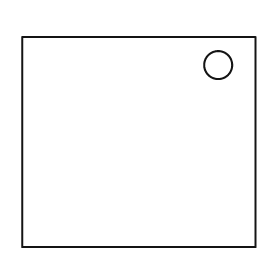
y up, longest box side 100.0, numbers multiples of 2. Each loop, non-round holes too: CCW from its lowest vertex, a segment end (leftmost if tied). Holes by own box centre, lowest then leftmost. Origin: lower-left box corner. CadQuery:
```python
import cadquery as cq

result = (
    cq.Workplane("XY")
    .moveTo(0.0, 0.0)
    .lineTo(100.0, 0.0)
    .lineTo(100.0, 90.0)
    .lineTo(0.0, 90.0)
    .close()
    .moveTo(84.0, 78.0)
    .circle(6.0)
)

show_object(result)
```